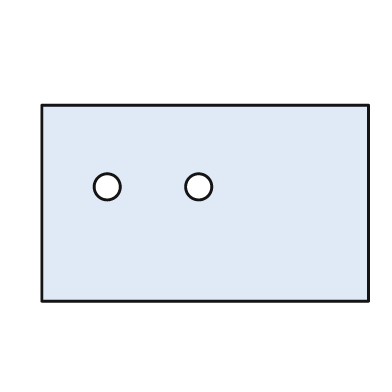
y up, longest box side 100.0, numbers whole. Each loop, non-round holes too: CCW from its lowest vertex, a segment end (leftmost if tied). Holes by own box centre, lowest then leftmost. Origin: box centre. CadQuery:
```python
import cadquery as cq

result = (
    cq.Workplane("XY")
    .moveTo(-50.0, -30.0)
    .lineTo(50.0, -30.0)
    .lineTo(50.0, 30.0)
    .lineTo(-50.0, 30.0)
    .close()
    .moveTo(-30.0, 5.0)
    .circle(4.0)
    .moveTo(-2.0, 5.0)
    .circle(4.0)
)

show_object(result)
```